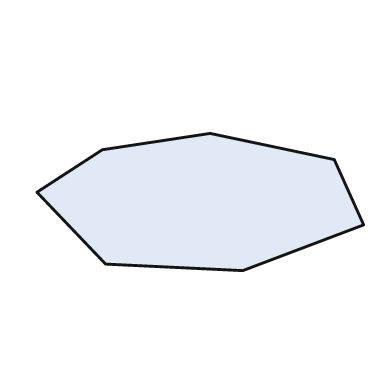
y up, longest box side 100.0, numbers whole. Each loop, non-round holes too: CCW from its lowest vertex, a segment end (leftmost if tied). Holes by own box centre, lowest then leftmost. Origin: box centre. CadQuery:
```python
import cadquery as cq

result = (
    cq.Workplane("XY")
    .moveTo(13.0, -21.0)
    .lineTo(50.0, -7.0)
    .lineTo(41.0, 13.0)
    .lineTo(3.0, 21.0)
    .lineTo(-30.0, 16.0)
    .lineTo(-50.0, 3.0)
    .lineTo(-29.0, -19.0)
    .close()
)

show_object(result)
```